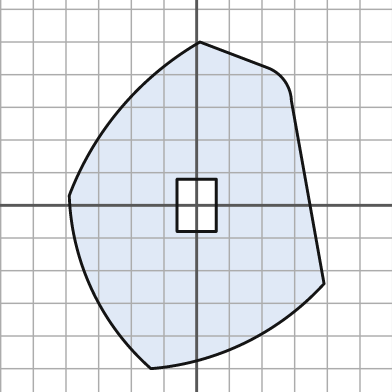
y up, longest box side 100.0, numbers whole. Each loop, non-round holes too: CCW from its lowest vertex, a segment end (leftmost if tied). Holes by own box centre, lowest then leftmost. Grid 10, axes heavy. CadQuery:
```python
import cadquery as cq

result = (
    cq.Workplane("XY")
    .moveTo(-14.0, -50.0)
    .threePointArc((15.0, -42.0), (39.0, -24.0))
    .lineTo(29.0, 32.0)
    .threePointArc((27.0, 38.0), (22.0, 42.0))
    .lineTo(1.0, 50.0)
    .threePointArc((-23.0, 30.0), (-39.0, 3.0))
    .threePointArc((-32.0, -26.0), (-14.0, -50.0))
    .close()
    .moveTo(-6.0, -8.0)
    .lineTo(6.0, -8.0)
    .lineTo(6.0, 8.0)
    .lineTo(-6.0, 8.0)
    .close()
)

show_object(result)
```